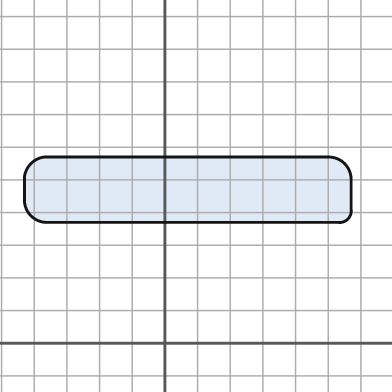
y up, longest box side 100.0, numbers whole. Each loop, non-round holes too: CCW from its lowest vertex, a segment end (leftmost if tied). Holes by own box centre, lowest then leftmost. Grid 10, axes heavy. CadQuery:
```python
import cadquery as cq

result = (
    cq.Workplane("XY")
    .moveTo(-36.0, 37.0)
    .lineTo(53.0, 37.0)
    .threePointArc((56.0, 38.0), (57.0, 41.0))
    .lineTo(57.0, 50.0)
    .threePointArc((55.0, 55.0), (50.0, 57.0))
    .lineTo(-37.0, 57.0)
    .threePointArc((-41.0, 55.0), (-43.0, 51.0))
    .lineTo(-43.0, 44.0)
    .threePointArc((-41.0, 39.0), (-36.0, 37.0))
    .close()
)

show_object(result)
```